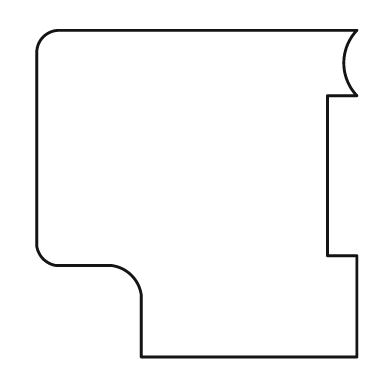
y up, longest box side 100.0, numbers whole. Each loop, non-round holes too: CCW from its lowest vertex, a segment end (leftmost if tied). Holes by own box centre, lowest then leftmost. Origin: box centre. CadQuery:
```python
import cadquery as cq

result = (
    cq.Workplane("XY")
    .moveTo(-17.0, -50.0)
    .lineTo(49.0, -50.0)
    .lineTo(49.0, -19.0)
    .lineTo(40.0, -19.0)
    .lineTo(40.0, 30.0)
    .lineTo(49.0, 30.0)
    .threePointArc((45.0, 40.0), (49.0, 50.0))
    .lineTo(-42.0, 50.0)
    .threePointArc((-47.0, 48.0), (-49.0, 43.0))
    .lineTo(-49.0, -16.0)
    .threePointArc((-47.0, -20.0), (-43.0, -22.0))
    .lineTo(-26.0, -22.0)
    .threePointArc((-20.0, -25.0), (-17.0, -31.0))
    .close()
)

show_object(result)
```